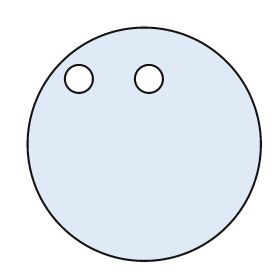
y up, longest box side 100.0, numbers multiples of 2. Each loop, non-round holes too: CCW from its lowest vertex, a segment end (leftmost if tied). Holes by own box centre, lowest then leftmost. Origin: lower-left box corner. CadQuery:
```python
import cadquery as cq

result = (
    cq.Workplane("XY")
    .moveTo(50.0, 50.0)
    .circle(50.0)
    .moveTo(22.0, 78.0)
    .circle(6.0)
    .moveTo(52.0, 78.0)
    .circle(6.0)
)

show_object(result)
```